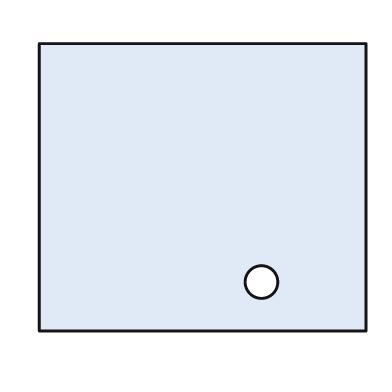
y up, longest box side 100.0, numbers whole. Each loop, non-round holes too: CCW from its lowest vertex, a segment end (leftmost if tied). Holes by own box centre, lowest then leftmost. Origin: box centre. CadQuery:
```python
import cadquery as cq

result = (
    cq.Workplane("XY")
    .moveTo(-50.0, -44.0)
    .lineTo(50.0, -44.0)
    .lineTo(50.0, 44.0)
    .lineTo(-50.0, 44.0)
    .close()
    .moveTo(18.0, -29.0)
    .circle(5.0)
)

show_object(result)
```